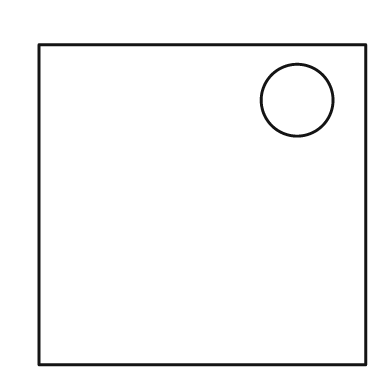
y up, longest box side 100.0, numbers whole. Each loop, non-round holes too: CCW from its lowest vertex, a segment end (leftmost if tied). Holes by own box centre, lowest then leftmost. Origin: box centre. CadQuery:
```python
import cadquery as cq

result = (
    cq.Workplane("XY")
    .moveTo(-50.0, -49.0)
    .lineTo(50.0, -49.0)
    .lineTo(50.0, 49.0)
    .lineTo(-50.0, 49.0)
    .close()
    .moveTo(29.0, 32.0)
    .circle(11.0)
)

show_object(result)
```